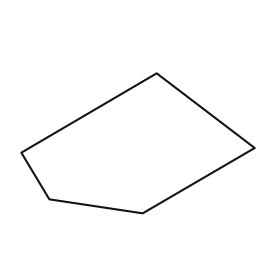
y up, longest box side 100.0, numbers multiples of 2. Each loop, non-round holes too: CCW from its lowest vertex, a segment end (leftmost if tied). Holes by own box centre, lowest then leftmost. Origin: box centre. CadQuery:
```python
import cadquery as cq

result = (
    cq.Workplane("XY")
    .moveTo(2.0, -30.0)
    .lineTo(50.0, -2.0)
    .lineTo(8.0, 30.0)
    .lineTo(-50.0, -4.0)
    .lineTo(-38.0, -24.0)
    .close()
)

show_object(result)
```